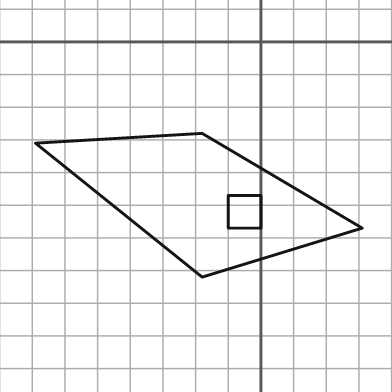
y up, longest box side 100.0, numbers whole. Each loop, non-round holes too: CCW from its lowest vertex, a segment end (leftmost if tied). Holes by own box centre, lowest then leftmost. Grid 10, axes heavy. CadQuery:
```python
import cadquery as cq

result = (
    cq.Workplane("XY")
    .moveTo(-18.0, -72.0)
    .lineTo(31.0, -57.0)
    .lineTo(-18.0, -28.0)
    .lineTo(-69.0, -31.0)
    .close()
    .moveTo(-10.0, -57.0)
    .lineTo(0.0, -57.0)
    .lineTo(0.0, -47.0)
    .lineTo(-10.0, -47.0)
    .close()
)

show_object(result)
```